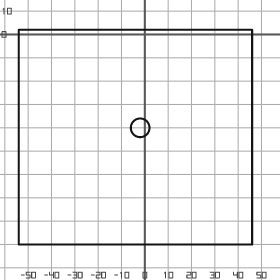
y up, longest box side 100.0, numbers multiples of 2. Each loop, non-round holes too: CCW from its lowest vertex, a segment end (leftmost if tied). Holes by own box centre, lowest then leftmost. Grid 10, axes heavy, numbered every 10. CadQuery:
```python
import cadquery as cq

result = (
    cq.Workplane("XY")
    .moveTo(-54.0, -90.0)
    .lineTo(46.0, -90.0)
    .lineTo(46.0, 2.0)
    .lineTo(-54.0, 2.0)
    .close()
    .moveTo(-2.0, -40.0)
    .circle(4.0)
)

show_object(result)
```